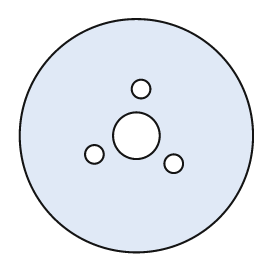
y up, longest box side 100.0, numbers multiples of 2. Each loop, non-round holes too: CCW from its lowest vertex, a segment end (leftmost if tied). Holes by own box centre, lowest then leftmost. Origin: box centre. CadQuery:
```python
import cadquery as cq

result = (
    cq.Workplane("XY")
    .moveTo(0.0, 0.0)
    .circle(50.0)
    .moveTo(16.0, -12.0)
    .circle(4.0)
    .moveTo(-18.0, -8.0)
    .circle(4.0)
    .moveTo(0.0, 0.0)
    .circle(10.0)
    .moveTo(2.0, 20.0)
    .circle(4.0)
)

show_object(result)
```